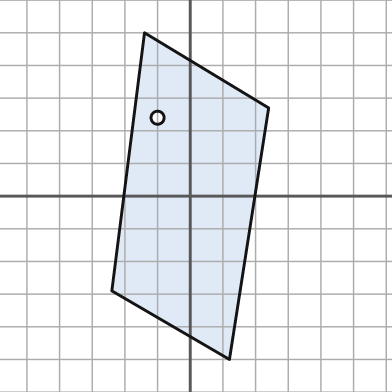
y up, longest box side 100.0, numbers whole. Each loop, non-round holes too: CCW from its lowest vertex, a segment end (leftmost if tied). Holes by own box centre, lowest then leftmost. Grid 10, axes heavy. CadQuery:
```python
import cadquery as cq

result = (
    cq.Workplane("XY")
    .moveTo(12.0, -50.0)
    .lineTo(24.0, 27.0)
    .lineTo(-14.0, 50.0)
    .lineTo(-24.0, -29.0)
    .close()
    .moveTo(-10.0, 24.0)
    .circle(2.0)
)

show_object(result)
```